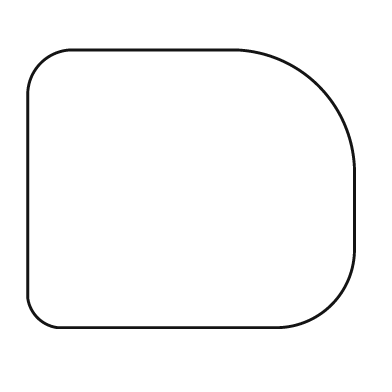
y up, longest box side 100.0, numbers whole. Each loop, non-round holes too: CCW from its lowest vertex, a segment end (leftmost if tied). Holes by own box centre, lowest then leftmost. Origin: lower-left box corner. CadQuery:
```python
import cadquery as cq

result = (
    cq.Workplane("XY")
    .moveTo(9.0, 0.0)
    .lineTo(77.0, 0.0)
    .threePointArc((93.0, 7.0), (100.0, 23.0))
    .lineTo(100.0, 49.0)
    .threePointArc((89.0, 74.0), (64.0, 85.0))
    .lineTo(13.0, 85.0)
    .threePointArc((4.0, 81.0), (0.0, 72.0))
    .lineTo(0.0, 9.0)
    .threePointArc((3.0, 3.0), (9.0, 0.0))
    .close()
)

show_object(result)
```